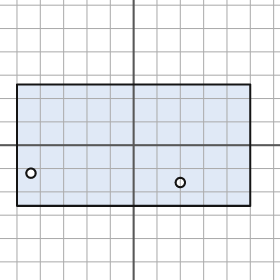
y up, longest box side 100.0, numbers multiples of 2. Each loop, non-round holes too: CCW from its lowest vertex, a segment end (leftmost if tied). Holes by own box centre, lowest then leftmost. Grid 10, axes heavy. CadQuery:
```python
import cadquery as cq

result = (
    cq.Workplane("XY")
    .moveTo(-50.0, -26.0)
    .lineTo(50.0, -26.0)
    .lineTo(50.0, 26.0)
    .lineTo(-50.0, 26.0)
    .close()
    .moveTo(20.0, -16.0)
    .circle(2.0)
    .moveTo(-44.0, -12.0)
    .circle(2.0)
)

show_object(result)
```